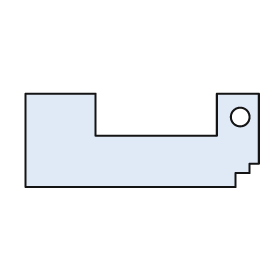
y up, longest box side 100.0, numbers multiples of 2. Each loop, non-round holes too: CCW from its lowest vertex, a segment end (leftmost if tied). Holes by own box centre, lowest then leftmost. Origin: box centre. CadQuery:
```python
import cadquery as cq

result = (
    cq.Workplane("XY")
    .moveTo(-50.0, -20.0)
    .lineTo(40.0, -20.0)
    .lineTo(40.0, -14.0)
    .lineTo(46.0, -14.0)
    .lineTo(46.0, -10.0)
    .lineTo(50.0, -10.0)
    .lineTo(50.0, 20.0)
    .lineTo(32.0, 20.0)
    .lineTo(32.0, 2.0)
    .lineTo(-20.0, 2.0)
    .lineTo(-20.0, 20.0)
    .lineTo(-50.0, 20.0)
    .close()
    .moveTo(42.0, 10.0)
    .circle(4.0)
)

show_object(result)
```